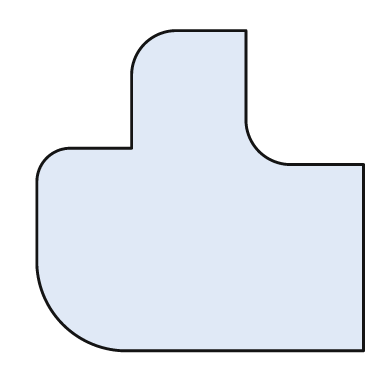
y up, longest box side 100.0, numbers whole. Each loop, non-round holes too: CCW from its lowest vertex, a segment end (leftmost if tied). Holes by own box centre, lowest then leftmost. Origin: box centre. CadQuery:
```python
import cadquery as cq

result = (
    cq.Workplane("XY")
    .moveTo(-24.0, -49.0)
    .lineTo(50.0, -49.0)
    .lineTo(50.0, 8.0)
    .lineTo(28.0, 8.0)
    .threePointArc((18.0, 12.0), (14.0, 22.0))
    .lineTo(14.0, 49.0)
    .lineTo(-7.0, 49.0)
    .threePointArc((-17.0, 45.0), (-21.0, 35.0))
    .lineTo(-21.0, 13.0)
    .lineTo(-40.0, 13.0)
    .threePointArc((-47.0, 10.0), (-50.0, 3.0))
    .lineTo(-50.0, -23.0)
    .threePointArc((-42.0, -41.0), (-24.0, -49.0))
    .close()
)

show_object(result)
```